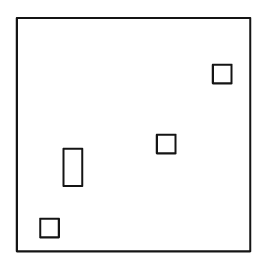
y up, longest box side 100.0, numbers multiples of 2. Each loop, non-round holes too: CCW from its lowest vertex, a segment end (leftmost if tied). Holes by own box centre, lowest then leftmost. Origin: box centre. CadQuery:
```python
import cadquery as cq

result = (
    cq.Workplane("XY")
    .moveTo(-50.0, -50.0)
    .lineTo(50.0, -50.0)
    .lineTo(50.0, 50.0)
    .lineTo(-50.0, 50.0)
    .close()
    .moveTo(-40.0, -44.0)
    .lineTo(-32.0, -44.0)
    .lineTo(-32.0, -36.0)
    .lineTo(-40.0, -36.0)
    .close()
    .moveTo(-30.0, -22.0)
    .lineTo(-22.0, -22.0)
    .lineTo(-22.0, -6.0)
    .lineTo(-30.0, -6.0)
    .close()
    .moveTo(10.0, -8.0)
    .lineTo(18.0, -8.0)
    .lineTo(18.0, 0.0)
    .lineTo(10.0, 0.0)
    .close()
    .moveTo(34.0, 22.0)
    .lineTo(42.0, 22.0)
    .lineTo(42.0, 30.0)
    .lineTo(34.0, 30.0)
    .close()
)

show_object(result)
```